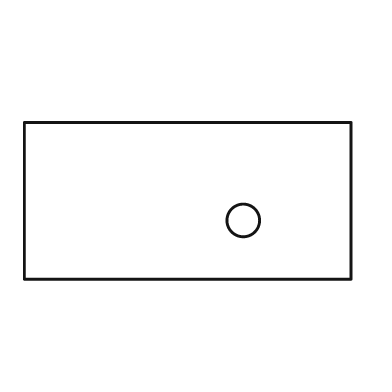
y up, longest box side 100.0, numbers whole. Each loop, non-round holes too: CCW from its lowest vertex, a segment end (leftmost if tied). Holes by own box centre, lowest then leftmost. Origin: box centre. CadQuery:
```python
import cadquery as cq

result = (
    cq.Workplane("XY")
    .moveTo(-50.0, -24.0)
    .lineTo(50.0, -24.0)
    .lineTo(50.0, 24.0)
    .lineTo(-50.0, 24.0)
    .close()
    .moveTo(17.0, -6.0)
    .circle(5.0)
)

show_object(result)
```